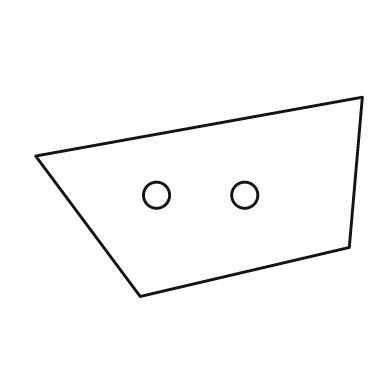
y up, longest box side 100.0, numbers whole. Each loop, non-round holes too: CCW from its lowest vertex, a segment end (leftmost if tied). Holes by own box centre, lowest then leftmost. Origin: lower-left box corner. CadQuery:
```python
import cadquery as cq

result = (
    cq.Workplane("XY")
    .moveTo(32.0, 0.0)
    .lineTo(96.0, 15.0)
    .lineTo(100.0, 61.0)
    .lineTo(0.0, 43.0)
    .close()
    .moveTo(37.0, 31.0)
    .circle(4.0)
    .moveTo(64.0, 31.0)
    .circle(4.0)
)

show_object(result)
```